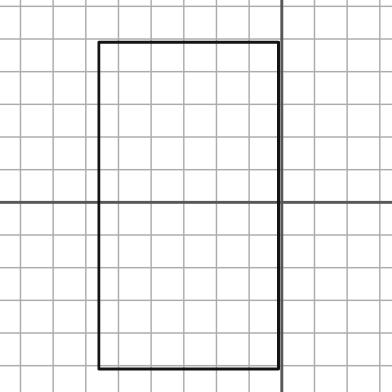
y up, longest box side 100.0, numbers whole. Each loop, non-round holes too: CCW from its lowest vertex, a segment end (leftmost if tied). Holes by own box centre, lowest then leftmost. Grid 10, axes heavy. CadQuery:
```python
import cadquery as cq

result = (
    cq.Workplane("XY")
    .moveTo(-56.0, -51.0)
    .lineTo(-1.0, -51.0)
    .lineTo(-1.0, 49.0)
    .lineTo(-56.0, 49.0)
    .close()
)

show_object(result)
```